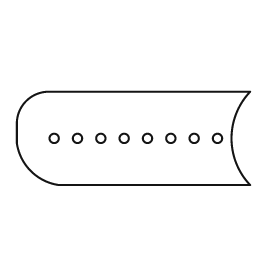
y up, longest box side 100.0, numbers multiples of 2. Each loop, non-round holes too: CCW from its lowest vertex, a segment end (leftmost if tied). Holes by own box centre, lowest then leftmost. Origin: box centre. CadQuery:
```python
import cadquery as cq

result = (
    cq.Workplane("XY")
    .moveTo(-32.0, -20.0)
    .lineTo(50.0, -20.0)
    .threePointArc((42.0, 0.0), (50.0, 20.0))
    .lineTo(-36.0, 20.0)
    .threePointArc((-46.0, 16.0), (-50.0, 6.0))
    .lineTo(-50.0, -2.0)
    .threePointArc((-44.0, -14.0), (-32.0, -20.0))
    .close()
    .moveTo(-34.0, 0.0)
    .circle(2.0)
    .moveTo(-24.0, 0.0)
    .circle(2.0)
    .moveTo(-14.0, 0.0)
    .circle(2.0)
    .moveTo(-4.0, 0.0)
    .circle(2.0)
    .moveTo(6.0, 0.0)
    .circle(2.0)
    .moveTo(16.0, 0.0)
    .circle(2.0)
    .moveTo(26.0, 0.0)
    .circle(2.0)
    .moveTo(36.0, 0.0)
    .circle(2.0)
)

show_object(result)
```